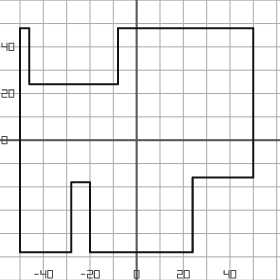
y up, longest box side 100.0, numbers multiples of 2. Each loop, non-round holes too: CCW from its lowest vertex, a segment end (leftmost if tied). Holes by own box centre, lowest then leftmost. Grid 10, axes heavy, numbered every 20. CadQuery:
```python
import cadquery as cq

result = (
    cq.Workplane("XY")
    .moveTo(-50.0, -48.0)
    .lineTo(-28.0, -48.0)
    .lineTo(-28.0, -18.0)
    .lineTo(-20.0, -18.0)
    .lineTo(-20.0, -48.0)
    .lineTo(24.0, -48.0)
    .lineTo(24.0, -16.0)
    .lineTo(50.0, -16.0)
    .lineTo(50.0, 48.0)
    .lineTo(-8.0, 48.0)
    .lineTo(-8.0, 24.0)
    .lineTo(-46.0, 24.0)
    .lineTo(-46.0, 48.0)
    .lineTo(-50.0, 48.0)
    .close()
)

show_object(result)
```